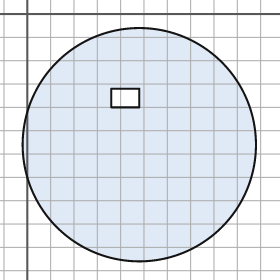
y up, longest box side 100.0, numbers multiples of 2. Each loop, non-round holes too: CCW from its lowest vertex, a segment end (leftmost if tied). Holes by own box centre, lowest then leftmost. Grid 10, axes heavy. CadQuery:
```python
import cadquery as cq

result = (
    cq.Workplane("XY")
    .moveTo(48.0, -56.0)
    .circle(50.0)
    .moveTo(36.0, -40.0)
    .lineTo(48.0, -40.0)
    .lineTo(48.0, -32.0)
    .lineTo(36.0, -32.0)
    .close()
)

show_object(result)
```